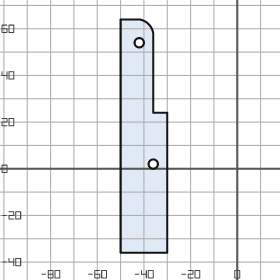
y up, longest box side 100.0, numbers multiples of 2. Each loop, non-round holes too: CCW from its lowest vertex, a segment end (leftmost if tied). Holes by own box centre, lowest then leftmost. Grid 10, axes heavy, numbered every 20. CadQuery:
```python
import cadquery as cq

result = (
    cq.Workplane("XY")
    .moveTo(-50.0, -36.0)
    .lineTo(-30.0, -36.0)
    .lineTo(-30.0, 24.0)
    .lineTo(-36.0, 24.0)
    .lineTo(-36.0, 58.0)
    .threePointArc((-38.0, 62.0), (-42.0, 64.0))
    .lineTo(-50.0, 64.0)
    .close()
    .moveTo(-36.0, 2.0)
    .circle(2.0)
    .moveTo(-42.0, 54.0)
    .circle(2.0)
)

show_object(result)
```